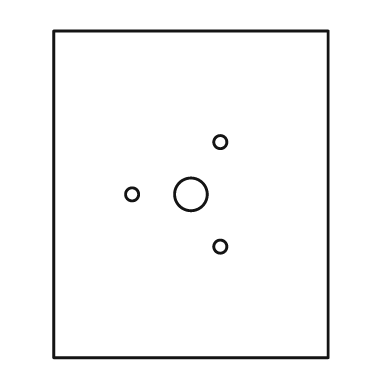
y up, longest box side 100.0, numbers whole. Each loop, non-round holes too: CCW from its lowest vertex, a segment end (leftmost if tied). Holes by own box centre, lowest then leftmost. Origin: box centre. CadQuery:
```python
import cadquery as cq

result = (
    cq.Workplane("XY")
    .moveTo(-42.0, -50.0)
    .lineTo(42.0, -50.0)
    .lineTo(42.0, 50.0)
    .lineTo(-42.0, 50.0)
    .close()
    .moveTo(9.0, -16.0)
    .circle(2.0)
    .moveTo(-18.0, 0.0)
    .circle(2.0)
    .moveTo(0.0, 0.0)
    .circle(5.0)
    .moveTo(9.0, 16.0)
    .circle(2.0)
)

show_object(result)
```